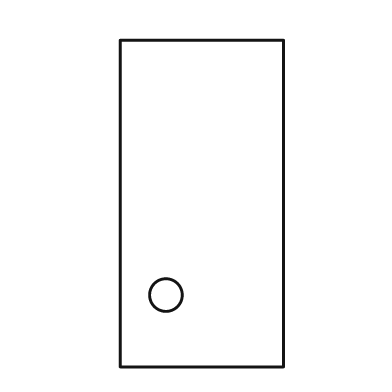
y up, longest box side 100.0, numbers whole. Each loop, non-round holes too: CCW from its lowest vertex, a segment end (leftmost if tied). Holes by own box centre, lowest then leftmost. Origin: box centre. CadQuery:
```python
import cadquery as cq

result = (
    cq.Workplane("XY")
    .moveTo(-25.0, -50.0)
    .lineTo(25.0, -50.0)
    .lineTo(25.0, 50.0)
    .lineTo(-25.0, 50.0)
    .close()
    .moveTo(-11.0, -28.0)
    .circle(5.0)
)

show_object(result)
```